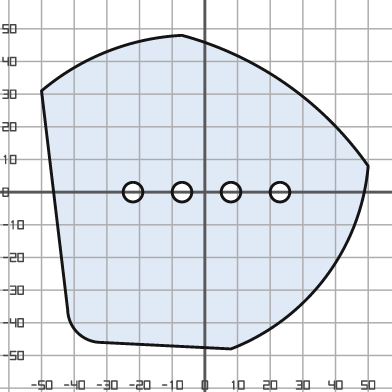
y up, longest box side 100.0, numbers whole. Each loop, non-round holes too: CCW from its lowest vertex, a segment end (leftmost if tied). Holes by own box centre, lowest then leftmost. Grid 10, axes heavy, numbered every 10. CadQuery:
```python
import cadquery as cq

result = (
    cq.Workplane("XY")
    .moveTo(8.0, -48.0)
    .threePointArc((37.0, -26.0), (50.0, 8.0))
    .threePointArc((25.0, 33.0), (-7.0, 48.0))
    .threePointArc((-30.0, 43.0), (-50.0, 31.0))
    .lineTo(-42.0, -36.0)
    .threePointArc((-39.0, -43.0), (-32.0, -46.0))
    .close()
    .moveTo(-22.0, 0.0)
    .circle(3.0)
    .moveTo(-7.0, 0.0)
    .circle(3.0)
    .moveTo(8.0, 0.0)
    .circle(3.0)
    .moveTo(23.0, 0.0)
    .circle(3.0)
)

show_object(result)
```